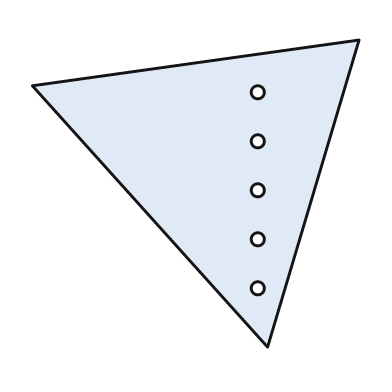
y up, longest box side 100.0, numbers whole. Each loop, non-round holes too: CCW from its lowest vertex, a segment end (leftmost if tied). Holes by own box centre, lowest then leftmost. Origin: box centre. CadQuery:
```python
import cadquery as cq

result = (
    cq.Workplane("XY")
    .moveTo(22.0, -47.0)
    .lineTo(50.0, 47.0)
    .lineTo(-50.0, 33.0)
    .close()
    .moveTo(19.0, -29.0)
    .circle(2.0)
    .moveTo(19.0, -14.0)
    .circle(2.0)
    .moveTo(19.0, 1.0)
    .circle(2.0)
    .moveTo(19.0, 16.0)
    .circle(2.0)
    .moveTo(19.0, 31.0)
    .circle(2.0)
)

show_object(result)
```